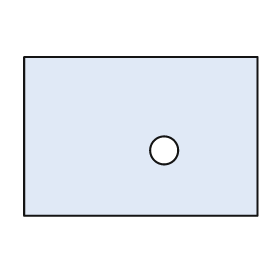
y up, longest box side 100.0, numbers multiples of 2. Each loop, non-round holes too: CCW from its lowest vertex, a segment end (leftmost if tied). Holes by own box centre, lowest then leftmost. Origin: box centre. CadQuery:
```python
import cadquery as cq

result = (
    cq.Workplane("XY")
    .moveTo(-50.0, -34.0)
    .lineTo(50.0, -34.0)
    .lineTo(50.0, 34.0)
    .lineTo(-50.0, 34.0)
    .close()
    .moveTo(10.0, -6.0)
    .circle(6.0)
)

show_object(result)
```